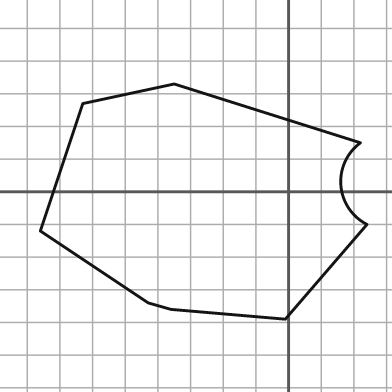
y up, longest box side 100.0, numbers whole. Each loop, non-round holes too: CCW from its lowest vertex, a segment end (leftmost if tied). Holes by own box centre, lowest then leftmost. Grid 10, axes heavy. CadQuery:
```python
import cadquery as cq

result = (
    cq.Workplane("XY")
    .moveTo(-1.0, -39.0)
    .lineTo(24.0, -10.0)
    .threePointArc((16.0, 2.0), (22.0, 15.0))
    .lineTo(-35.0, 33.0)
    .lineTo(-63.0, 27.0)
    .lineTo(-76.0, -12.0)
    .lineTo(-43.0, -34.0)
    .lineTo(-36.0, -36.0)
    .close()
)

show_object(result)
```